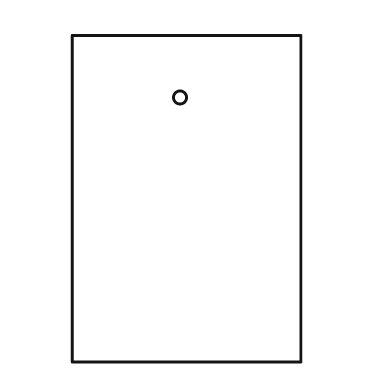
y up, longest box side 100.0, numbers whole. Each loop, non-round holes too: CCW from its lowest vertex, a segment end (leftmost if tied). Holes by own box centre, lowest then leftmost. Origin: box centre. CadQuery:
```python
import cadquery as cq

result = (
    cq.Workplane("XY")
    .moveTo(-35.0, -50.0)
    .lineTo(35.0, -50.0)
    .lineTo(35.0, 50.0)
    .lineTo(-35.0, 50.0)
    .close()
    .moveTo(-2.0, 31.0)
    .circle(2.0)
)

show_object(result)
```